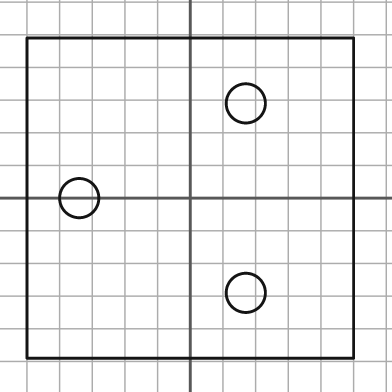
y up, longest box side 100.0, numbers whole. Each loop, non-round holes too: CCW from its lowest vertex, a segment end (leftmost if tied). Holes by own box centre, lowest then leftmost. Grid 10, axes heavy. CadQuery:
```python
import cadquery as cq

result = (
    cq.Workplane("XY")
    .moveTo(-50.0, -49.0)
    .lineTo(50.0, -49.0)
    .lineTo(50.0, 49.0)
    .lineTo(-50.0, 49.0)
    .close()
    .moveTo(17.0, -29.0)
    .circle(6.0)
    .moveTo(-34.0, 0.0)
    .circle(6.0)
    .moveTo(17.0, 29.0)
    .circle(6.0)
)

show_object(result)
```